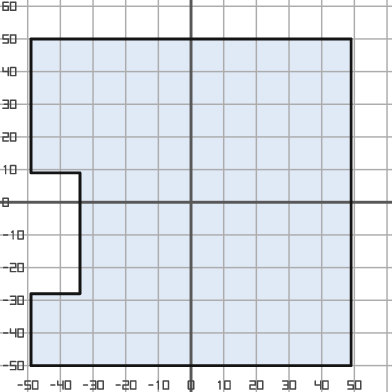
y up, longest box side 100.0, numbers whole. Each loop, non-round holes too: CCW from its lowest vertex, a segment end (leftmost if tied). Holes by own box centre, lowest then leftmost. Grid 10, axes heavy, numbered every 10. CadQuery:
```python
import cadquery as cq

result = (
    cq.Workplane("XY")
    .moveTo(-49.0, -50.0)
    .lineTo(49.0, -50.0)
    .lineTo(49.0, 50.0)
    .lineTo(-49.0, 50.0)
    .lineTo(-49.0, 9.0)
    .lineTo(-34.0, 9.0)
    .lineTo(-34.0, -28.0)
    .lineTo(-49.0, -28.0)
    .close()
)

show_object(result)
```